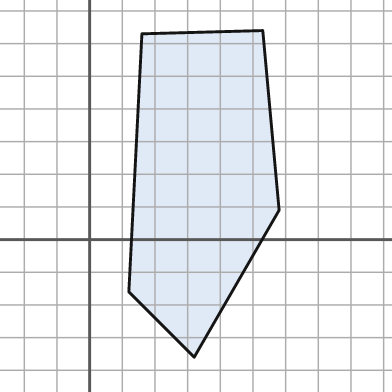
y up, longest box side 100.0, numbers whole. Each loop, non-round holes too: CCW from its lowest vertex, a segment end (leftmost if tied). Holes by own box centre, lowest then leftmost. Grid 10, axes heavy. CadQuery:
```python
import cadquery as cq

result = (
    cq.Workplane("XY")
    .moveTo(32.0, -36.0)
    .lineTo(58.0, 9.0)
    .lineTo(53.0, 64.0)
    .lineTo(16.0, 63.0)
    .lineTo(12.0, -16.0)
    .close()
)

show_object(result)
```